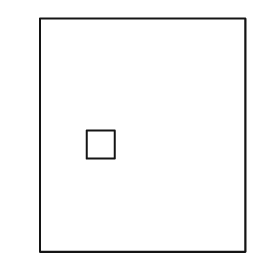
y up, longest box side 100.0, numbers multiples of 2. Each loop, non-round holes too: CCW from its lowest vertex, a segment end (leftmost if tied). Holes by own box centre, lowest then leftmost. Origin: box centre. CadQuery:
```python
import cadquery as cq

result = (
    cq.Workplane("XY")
    .moveTo(-44.0, -50.0)
    .lineTo(44.0, -50.0)
    .lineTo(44.0, 50.0)
    .lineTo(-44.0, 50.0)
    .close()
    .moveTo(-24.0, -10.0)
    .lineTo(-12.0, -10.0)
    .lineTo(-12.0, 2.0)
    .lineTo(-24.0, 2.0)
    .close()
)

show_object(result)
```